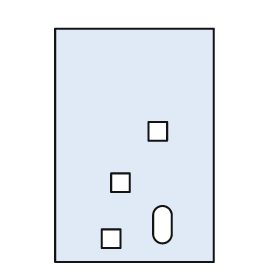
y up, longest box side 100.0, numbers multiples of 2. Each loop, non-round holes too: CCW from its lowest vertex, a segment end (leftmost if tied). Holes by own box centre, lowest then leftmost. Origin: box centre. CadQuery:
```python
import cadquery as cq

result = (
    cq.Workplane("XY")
    .moveTo(-34.0, -50.0)
    .lineTo(34.0, -50.0)
    .lineTo(34.0, 50.0)
    .lineTo(-34.0, 50.0)
    .close()
    .moveTo(-14.0, -44.0)
    .lineTo(-6.0, -44.0)
    .lineTo(-6.0, -36.0)
    .lineTo(-14.0, -36.0)
    .close()
    .moveTo(8.0, -38.0)
    .threePointArc((12.0, -42.0), (16.0, -38.0))
    .lineTo(16.0, -30.0)
    .threePointArc((12.0, -26.0), (8.0, -30.0))
    .close()
    .moveTo(-10.0, -20.0)
    .lineTo(-2.0, -20.0)
    .lineTo(-2.0, -12.0)
    .lineTo(-10.0, -12.0)
    .close()
    .moveTo(6.0, 2.0)
    .lineTo(14.0, 2.0)
    .lineTo(14.0, 10.0)
    .lineTo(6.0, 10.0)
    .close()
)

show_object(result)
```